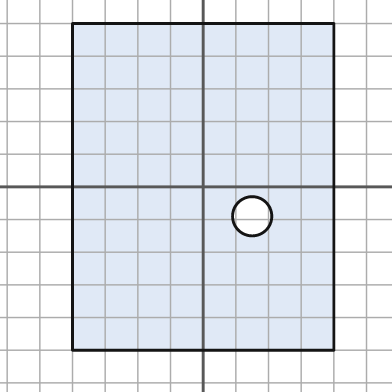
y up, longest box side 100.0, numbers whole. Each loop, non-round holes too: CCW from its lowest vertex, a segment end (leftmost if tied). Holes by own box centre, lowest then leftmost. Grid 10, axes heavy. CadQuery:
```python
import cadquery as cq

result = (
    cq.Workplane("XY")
    .moveTo(-40.0, -50.0)
    .lineTo(40.0, -50.0)
    .lineTo(40.0, 50.0)
    .lineTo(-40.0, 50.0)
    .close()
    .moveTo(15.0, -9.0)
    .circle(6.0)
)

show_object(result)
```